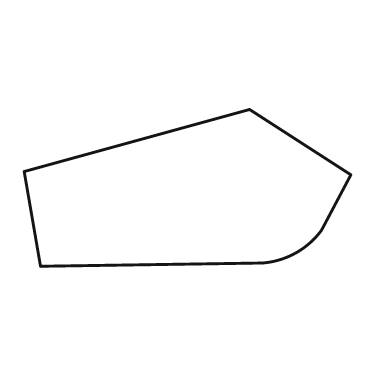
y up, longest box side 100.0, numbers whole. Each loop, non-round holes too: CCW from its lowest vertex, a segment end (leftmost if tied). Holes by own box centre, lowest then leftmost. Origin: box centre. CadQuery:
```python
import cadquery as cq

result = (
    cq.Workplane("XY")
    .moveTo(-45.0, -24.0)
    .lineTo(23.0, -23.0)
    .threePointArc((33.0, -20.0), (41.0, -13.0))
    .lineTo(50.0, 4.0)
    .lineTo(19.0, 24.0)
    .lineTo(-50.0, 5.0)
    .close()
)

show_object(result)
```